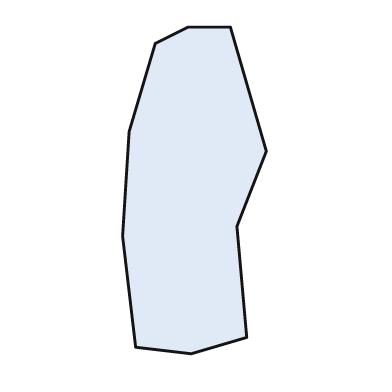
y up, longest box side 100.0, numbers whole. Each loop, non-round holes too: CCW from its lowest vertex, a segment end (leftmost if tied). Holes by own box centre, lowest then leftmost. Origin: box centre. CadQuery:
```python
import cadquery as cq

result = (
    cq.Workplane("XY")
    .moveTo(-1.0, -50.0)
    .lineTo(16.0, -45.0)
    .lineTo(13.0, -11.0)
    .lineTo(22.0, 12.0)
    .lineTo(11.0, 50.0)
    .lineTo(-2.0, 50.0)
    .lineTo(-12.0, 45.0)
    .lineTo(-20.0, 18.0)
    .lineTo(-22.0, -14.0)
    .lineTo(-18.0, -48.0)
    .close()
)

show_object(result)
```